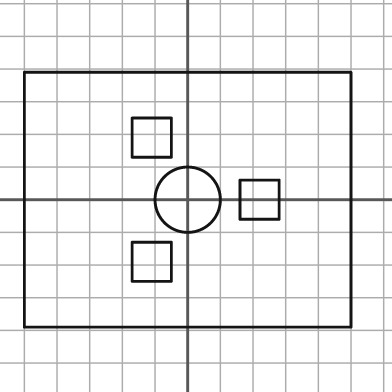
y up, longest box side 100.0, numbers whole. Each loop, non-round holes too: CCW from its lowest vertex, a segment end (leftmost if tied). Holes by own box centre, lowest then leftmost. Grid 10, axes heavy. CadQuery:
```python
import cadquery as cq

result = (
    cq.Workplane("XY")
    .moveTo(-50.0, -39.0)
    .lineTo(50.0, -39.0)
    .lineTo(50.0, 39.0)
    .lineTo(-50.0, 39.0)
    .close()
    .moveTo(-17.0, -25.0)
    .lineTo(-5.0, -25.0)
    .lineTo(-5.0, -13.0)
    .lineTo(-17.0, -13.0)
    .close()
    .moveTo(0.0, 0.0)
    .circle(10.0)
    .moveTo(16.0, -6.0)
    .lineTo(28.0, -6.0)
    .lineTo(28.0, 6.0)
    .lineTo(16.0, 6.0)
    .close()
    .moveTo(-17.0, 13.0)
    .lineTo(-5.0, 13.0)
    .lineTo(-5.0, 25.0)
    .lineTo(-17.0, 25.0)
    .close()
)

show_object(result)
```